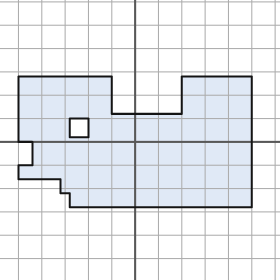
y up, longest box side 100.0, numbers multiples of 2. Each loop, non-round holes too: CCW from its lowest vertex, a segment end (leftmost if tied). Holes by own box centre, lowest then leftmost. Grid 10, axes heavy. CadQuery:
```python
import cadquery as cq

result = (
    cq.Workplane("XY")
    .moveTo(-28.0, -28.0)
    .lineTo(50.0, -28.0)
    .lineTo(50.0, 28.0)
    .lineTo(20.0, 28.0)
    .lineTo(20.0, 12.0)
    .lineTo(-10.0, 12.0)
    .lineTo(-10.0, 28.0)
    .lineTo(-50.0, 28.0)
    .lineTo(-50.0, 0.0)
    .lineTo(-44.0, 0.0)
    .lineTo(-44.0, -10.0)
    .lineTo(-50.0, -10.0)
    .lineTo(-50.0, -16.0)
    .lineTo(-32.0, -16.0)
    .lineTo(-32.0, -22.0)
    .lineTo(-28.0, -22.0)
    .close()
    .moveTo(-28.0, 2.0)
    .lineTo(-20.0, 2.0)
    .lineTo(-20.0, 10.0)
    .lineTo(-28.0, 10.0)
    .close()
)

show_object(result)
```